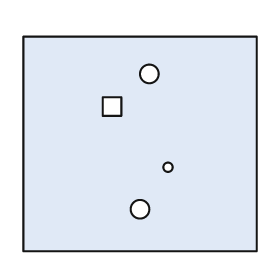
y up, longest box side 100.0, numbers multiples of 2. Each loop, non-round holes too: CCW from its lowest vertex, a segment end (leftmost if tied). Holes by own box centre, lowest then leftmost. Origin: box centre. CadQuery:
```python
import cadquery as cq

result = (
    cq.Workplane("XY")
    .moveTo(-50.0, -46.0)
    .lineTo(50.0, -46.0)
    .lineTo(50.0, 46.0)
    .lineTo(-50.0, 46.0)
    .close()
    .moveTo(0.0, -28.0)
    .circle(4.0)
    .moveTo(12.0, -10.0)
    .circle(2.0)
    .moveTo(-16.0, 12.0)
    .lineTo(-8.0, 12.0)
    .lineTo(-8.0, 20.0)
    .lineTo(-16.0, 20.0)
    .close()
    .moveTo(4.0, 30.0)
    .circle(4.0)
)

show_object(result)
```